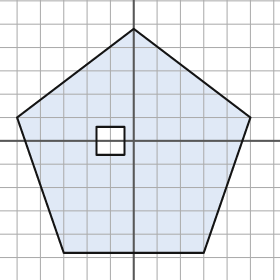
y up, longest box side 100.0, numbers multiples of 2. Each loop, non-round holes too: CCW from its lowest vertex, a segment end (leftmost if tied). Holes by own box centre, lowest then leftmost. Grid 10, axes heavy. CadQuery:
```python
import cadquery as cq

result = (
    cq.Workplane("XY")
    .moveTo(-30.0, -48.0)
    .lineTo(30.0, -48.0)
    .lineTo(50.0, 10.0)
    .lineTo(0.0, 48.0)
    .lineTo(-50.0, 10.0)
    .close()
    .moveTo(-16.0, -6.0)
    .lineTo(-4.0, -6.0)
    .lineTo(-4.0, 6.0)
    .lineTo(-16.0, 6.0)
    .close()
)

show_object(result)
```